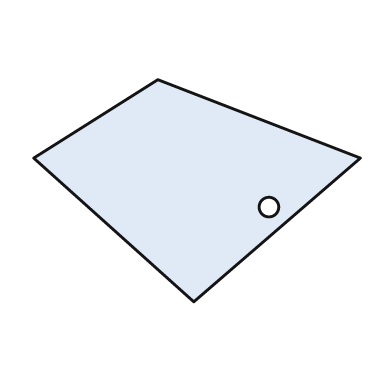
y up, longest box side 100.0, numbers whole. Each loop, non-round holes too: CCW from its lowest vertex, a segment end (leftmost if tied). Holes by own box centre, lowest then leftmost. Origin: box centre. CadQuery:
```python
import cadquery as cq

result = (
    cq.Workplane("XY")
    .moveTo(-1.0, -34.0)
    .lineTo(50.0, 10.0)
    .lineTo(-12.0, 34.0)
    .lineTo(-50.0, 10.0)
    .close()
    .moveTo(22.0, -5.0)
    .circle(3.0)
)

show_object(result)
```